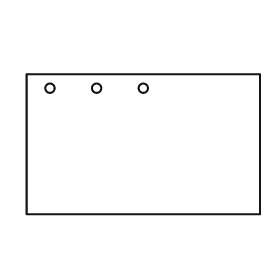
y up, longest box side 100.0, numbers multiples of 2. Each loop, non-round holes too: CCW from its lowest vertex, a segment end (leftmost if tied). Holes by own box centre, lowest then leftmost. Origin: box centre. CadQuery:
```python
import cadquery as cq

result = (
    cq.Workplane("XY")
    .moveTo(-50.0, -30.0)
    .lineTo(50.0, -30.0)
    .lineTo(50.0, 30.0)
    .lineTo(-50.0, 30.0)
    .close()
    .moveTo(-40.0, 24.0)
    .circle(2.0)
    .moveTo(-20.0, 24.0)
    .circle(2.0)
    .moveTo(0.0, 24.0)
    .circle(2.0)
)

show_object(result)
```